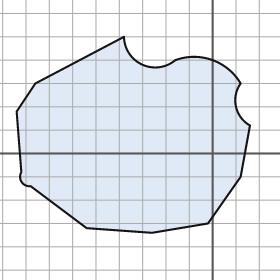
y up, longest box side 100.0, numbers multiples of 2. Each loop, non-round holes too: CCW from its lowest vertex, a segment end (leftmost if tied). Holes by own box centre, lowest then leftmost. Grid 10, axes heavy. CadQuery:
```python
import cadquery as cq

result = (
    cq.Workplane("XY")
    .moveTo(-26.0, -34.0)
    .lineTo(-2.0, -30.0)
    .lineTo(12.0, -10.0)
    .lineTo(16.0, 12.0)
    .threePointArc((10.0, 20.0), (12.0, 30.0))
    .threePointArc((0.0, 40.0), (-16.0, 40.0))
    .threePointArc((-30.0, 38.0), (-38.0, 50.0))
    .lineTo(-76.0, 30.0)
    .lineTo(-84.0, 18.0)
    .lineTo(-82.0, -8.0)
    .threePointArc((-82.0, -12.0), (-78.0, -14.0))
    .lineTo(-54.0, -32.0)
    .close()
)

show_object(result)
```